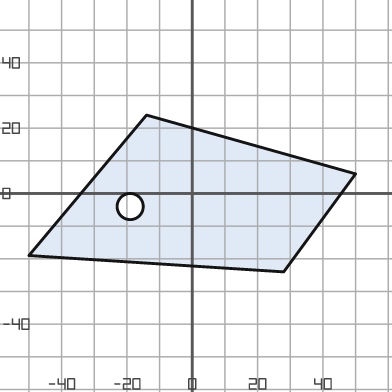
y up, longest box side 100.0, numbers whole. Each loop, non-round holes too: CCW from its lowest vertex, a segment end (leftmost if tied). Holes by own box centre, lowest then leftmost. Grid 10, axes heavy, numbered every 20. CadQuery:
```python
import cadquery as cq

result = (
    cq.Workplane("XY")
    .moveTo(28.0, -24.0)
    .lineTo(50.0, 6.0)
    .lineTo(-14.0, 24.0)
    .lineTo(-50.0, -19.0)
    .close()
    .moveTo(-19.0, -4.0)
    .circle(4.0)
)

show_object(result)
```